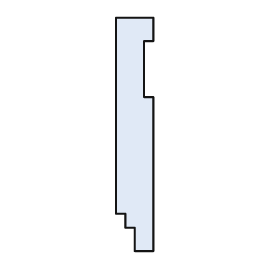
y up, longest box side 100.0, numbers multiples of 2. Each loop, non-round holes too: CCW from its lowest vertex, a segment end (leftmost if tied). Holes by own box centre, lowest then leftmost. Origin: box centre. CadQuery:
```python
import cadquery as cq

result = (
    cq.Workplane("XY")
    .moveTo(0.0, -50.0)
    .lineTo(8.0, -50.0)
    .lineTo(8.0, 16.0)
    .lineTo(4.0, 16.0)
    .lineTo(4.0, 40.0)
    .lineTo(8.0, 40.0)
    .lineTo(8.0, 50.0)
    .lineTo(-8.0, 50.0)
    .lineTo(-8.0, -34.0)
    .lineTo(-4.0, -34.0)
    .lineTo(-4.0, -40.0)
    .lineTo(0.0, -40.0)
    .close()
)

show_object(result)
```